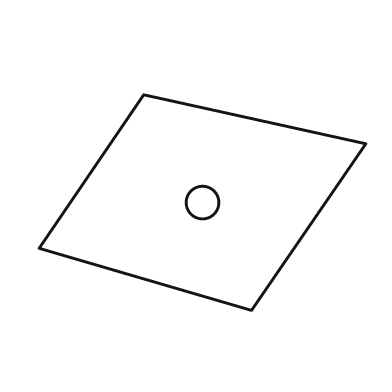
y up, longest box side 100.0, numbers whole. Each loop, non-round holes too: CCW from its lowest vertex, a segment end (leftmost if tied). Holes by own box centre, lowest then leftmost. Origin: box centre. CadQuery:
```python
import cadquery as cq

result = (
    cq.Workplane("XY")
    .moveTo(15.0, -33.0)
    .lineTo(50.0, 18.0)
    .lineTo(-18.0, 33.0)
    .lineTo(-50.0, -14.0)
    .close()
    .moveTo(0.0, 0.0)
    .circle(5.0)
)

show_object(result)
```